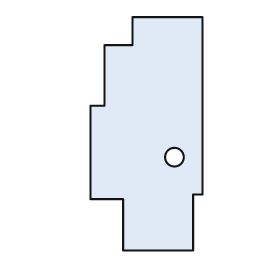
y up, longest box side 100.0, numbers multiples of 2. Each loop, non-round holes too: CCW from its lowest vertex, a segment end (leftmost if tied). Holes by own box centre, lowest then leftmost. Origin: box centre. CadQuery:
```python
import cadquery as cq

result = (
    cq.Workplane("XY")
    .moveTo(-10.0, -50.0)
    .lineTo(20.0, -50.0)
    .lineTo(20.0, -26.0)
    .lineTo(24.0, -26.0)
    .lineTo(24.0, 50.0)
    .lineTo(-6.0, 50.0)
    .lineTo(-6.0, 38.0)
    .lineTo(-18.0, 38.0)
    .lineTo(-18.0, 12.0)
    .lineTo(-24.0, 12.0)
    .lineTo(-24.0, -28.0)
    .lineTo(-10.0, -28.0)
    .close()
    .moveTo(12.0, -10.0)
    .circle(4.0)
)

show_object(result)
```